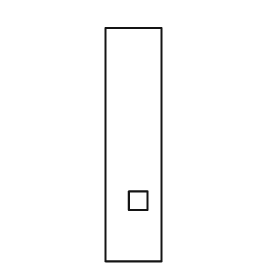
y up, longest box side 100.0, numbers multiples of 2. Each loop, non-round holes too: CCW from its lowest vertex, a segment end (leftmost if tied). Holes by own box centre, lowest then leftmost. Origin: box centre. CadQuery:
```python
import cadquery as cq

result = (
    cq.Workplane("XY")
    .moveTo(-12.0, -50.0)
    .lineTo(12.0, -50.0)
    .lineTo(12.0, 50.0)
    .lineTo(-12.0, 50.0)
    .close()
    .moveTo(-2.0, -28.0)
    .lineTo(6.0, -28.0)
    .lineTo(6.0, -20.0)
    .lineTo(-2.0, -20.0)
    .close()
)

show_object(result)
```